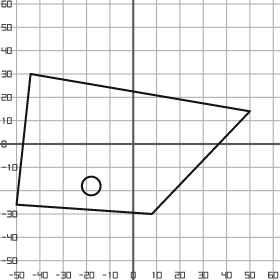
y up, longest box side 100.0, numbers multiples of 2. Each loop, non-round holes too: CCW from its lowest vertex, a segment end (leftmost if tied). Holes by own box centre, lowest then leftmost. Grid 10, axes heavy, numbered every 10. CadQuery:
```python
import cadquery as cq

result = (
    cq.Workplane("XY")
    .moveTo(8.0, -30.0)
    .lineTo(50.0, 14.0)
    .lineTo(-44.0, 30.0)
    .lineTo(-50.0, -26.0)
    .close()
    .moveTo(-18.0, -18.0)
    .circle(4.0)
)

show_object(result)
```